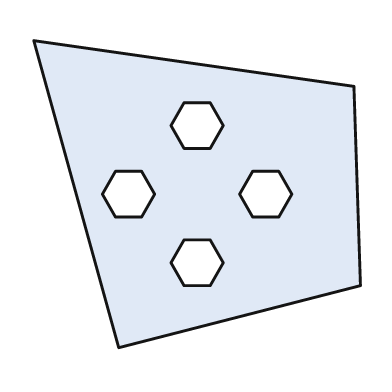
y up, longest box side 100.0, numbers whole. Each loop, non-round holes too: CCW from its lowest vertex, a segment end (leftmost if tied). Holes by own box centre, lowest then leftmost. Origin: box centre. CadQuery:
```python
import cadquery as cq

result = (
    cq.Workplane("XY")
    .moveTo(-24.0, -47.0)
    .lineTo(50.0, -28.0)
    .lineTo(48.0, 33.0)
    .lineTo(-50.0, 47.0)
    .close()
    .moveTo(-4.0, -28.0)
    .lineTo(4.0, -28.0)
    .lineTo(8.0, -21.0)
    .lineTo(4.0, -14.0)
    .lineTo(-4.0, -14.0)
    .lineTo(-8.0, -21.0)
    .close()
    .moveTo(-25.0, -7.0)
    .lineTo(-17.0, -7.0)
    .lineTo(-13.0, 0.0)
    .lineTo(-17.0, 7.0)
    .lineTo(-25.0, 7.0)
    .lineTo(-29.0, 0.0)
    .close()
    .moveTo(17.0, -7.0)
    .lineTo(25.0, -7.0)
    .lineTo(29.0, 0.0)
    .lineTo(25.0, 7.0)
    .lineTo(17.0, 7.0)
    .lineTo(13.0, 0.0)
    .close()
    .moveTo(-4.0, 14.0)
    .lineTo(4.0, 14.0)
    .lineTo(8.0, 21.0)
    .lineTo(4.0, 28.0)
    .lineTo(-4.0, 28.0)
    .lineTo(-8.0, 21.0)
    .close()
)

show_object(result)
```